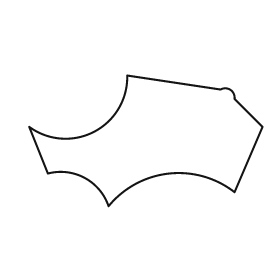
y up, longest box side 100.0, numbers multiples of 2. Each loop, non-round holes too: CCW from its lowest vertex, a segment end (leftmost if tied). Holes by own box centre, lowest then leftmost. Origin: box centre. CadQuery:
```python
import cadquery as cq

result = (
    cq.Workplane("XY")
    .moveTo(-16.0, -28.0)
    .threePointArc((10.0, -14.0), (38.0, -22.0))
    .lineTo(50.0, 6.0)
    .lineTo(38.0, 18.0)
    .threePointArc((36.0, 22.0), (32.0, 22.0))
    .lineTo(-8.0, 28.0)
    .threePointArc((-22.0, 4.0), (-50.0, 6.0))
    .lineTo(-42.0, -14.0)
    .threePointArc((-26.0, -16.0), (-16.0, -28.0))
    .close()
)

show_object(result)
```